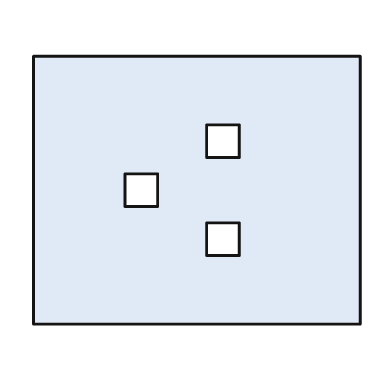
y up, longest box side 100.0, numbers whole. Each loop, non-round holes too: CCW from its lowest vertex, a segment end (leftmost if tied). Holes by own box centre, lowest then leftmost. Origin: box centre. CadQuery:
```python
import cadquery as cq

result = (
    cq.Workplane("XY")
    .moveTo(-50.0, -41.0)
    .lineTo(50.0, -41.0)
    .lineTo(50.0, 41.0)
    .lineTo(-50.0, 41.0)
    .close()
    .moveTo(3.0, -20.0)
    .lineTo(13.0, -20.0)
    .lineTo(13.0, -10.0)
    .lineTo(3.0, -10.0)
    .close()
    .moveTo(-22.0, -5.0)
    .lineTo(-12.0, -5.0)
    .lineTo(-12.0, 5.0)
    .lineTo(-22.0, 5.0)
    .close()
    .moveTo(3.0, 10.0)
    .lineTo(13.0, 10.0)
    .lineTo(13.0, 20.0)
    .lineTo(3.0, 20.0)
    .close()
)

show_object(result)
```